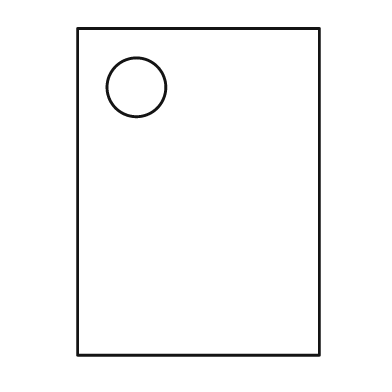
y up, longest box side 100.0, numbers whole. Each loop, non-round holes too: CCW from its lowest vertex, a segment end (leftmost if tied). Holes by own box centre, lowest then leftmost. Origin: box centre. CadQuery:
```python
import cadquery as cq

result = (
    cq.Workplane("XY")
    .moveTo(-37.0, -50.0)
    .lineTo(37.0, -50.0)
    .lineTo(37.0, 50.0)
    .lineTo(-37.0, 50.0)
    .close()
    .moveTo(-19.0, 32.0)
    .circle(9.0)
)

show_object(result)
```